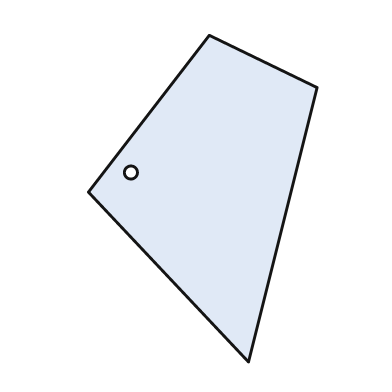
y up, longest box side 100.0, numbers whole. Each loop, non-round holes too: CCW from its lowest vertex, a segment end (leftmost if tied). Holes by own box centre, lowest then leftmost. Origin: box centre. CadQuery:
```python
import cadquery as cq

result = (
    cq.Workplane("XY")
    .moveTo(14.0, -50.0)
    .lineTo(35.0, 34.0)
    .lineTo(2.0, 50.0)
    .lineTo(-35.0, 2.0)
    .close()
    .moveTo(-22.0, 8.0)
    .circle(2.0)
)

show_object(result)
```